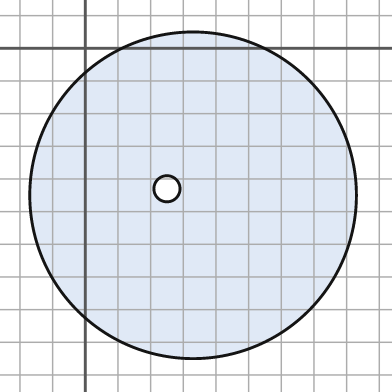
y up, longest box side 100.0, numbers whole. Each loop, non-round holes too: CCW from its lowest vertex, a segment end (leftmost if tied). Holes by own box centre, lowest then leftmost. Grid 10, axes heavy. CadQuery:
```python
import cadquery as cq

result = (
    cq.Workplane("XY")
    .moveTo(33.0, -45.0)
    .circle(50.0)
    .moveTo(25.0, -43.0)
    .circle(4.0)
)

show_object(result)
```